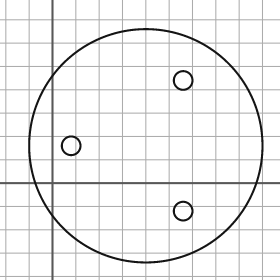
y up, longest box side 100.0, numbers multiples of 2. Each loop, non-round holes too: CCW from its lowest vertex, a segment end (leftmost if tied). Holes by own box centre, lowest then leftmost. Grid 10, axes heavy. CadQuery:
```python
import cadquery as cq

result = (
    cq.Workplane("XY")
    .moveTo(40.0, 16.0)
    .circle(50.0)
    .moveTo(56.0, -12.0)
    .circle(4.0)
    .moveTo(8.0, 16.0)
    .circle(4.0)
    .moveTo(56.0, 44.0)
    .circle(4.0)
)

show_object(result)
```